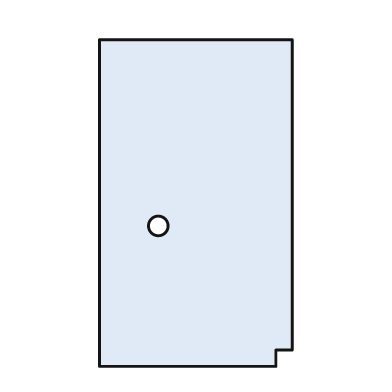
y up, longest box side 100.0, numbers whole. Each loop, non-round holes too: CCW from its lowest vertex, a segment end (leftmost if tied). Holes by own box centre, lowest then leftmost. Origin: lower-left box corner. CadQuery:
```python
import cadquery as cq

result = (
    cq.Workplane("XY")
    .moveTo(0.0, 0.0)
    .lineTo(54.0, 0.0)
    .lineTo(54.0, 5.0)
    .lineTo(59.0, 5.0)
    .lineTo(59.0, 100.0)
    .lineTo(0.0, 100.0)
    .close()
    .moveTo(18.0, 43.0)
    .circle(3.0)
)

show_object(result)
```